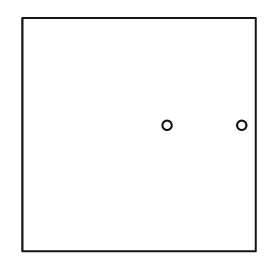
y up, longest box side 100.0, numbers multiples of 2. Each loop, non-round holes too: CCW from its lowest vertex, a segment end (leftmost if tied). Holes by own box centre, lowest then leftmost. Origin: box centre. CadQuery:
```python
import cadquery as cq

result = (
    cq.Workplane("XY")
    .moveTo(-50.0, -50.0)
    .lineTo(50.0, -50.0)
    .lineTo(50.0, 50.0)
    .lineTo(-50.0, 50.0)
    .close()
    .moveTo(12.0, 4.0)
    .circle(2.0)
    .moveTo(44.0, 4.0)
    .circle(2.0)
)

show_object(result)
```